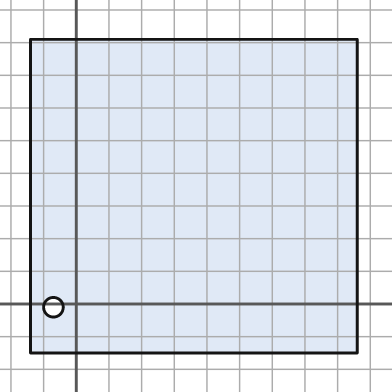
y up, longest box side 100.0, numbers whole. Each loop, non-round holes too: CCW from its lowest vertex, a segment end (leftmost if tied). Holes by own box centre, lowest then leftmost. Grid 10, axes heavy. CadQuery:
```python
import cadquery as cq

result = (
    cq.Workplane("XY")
    .moveTo(-14.0, -15.0)
    .lineTo(86.0, -15.0)
    .lineTo(86.0, 81.0)
    .lineTo(-14.0, 81.0)
    .close()
    .moveTo(-7.0, -1.0)
    .circle(3.0)
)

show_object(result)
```